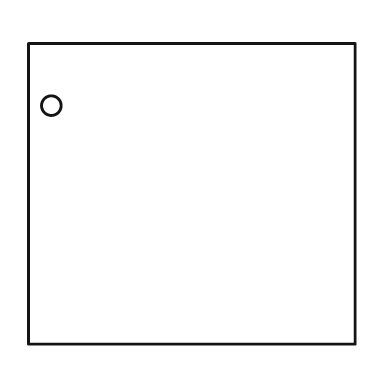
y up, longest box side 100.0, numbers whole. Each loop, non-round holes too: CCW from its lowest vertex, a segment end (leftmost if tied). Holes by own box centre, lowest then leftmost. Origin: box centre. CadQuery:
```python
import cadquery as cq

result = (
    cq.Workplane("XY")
    .moveTo(-50.0, -46.0)
    .lineTo(50.0, -46.0)
    .lineTo(50.0, 46.0)
    .lineTo(-50.0, 46.0)
    .close()
    .moveTo(-43.0, 27.0)
    .circle(3.0)
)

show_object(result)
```